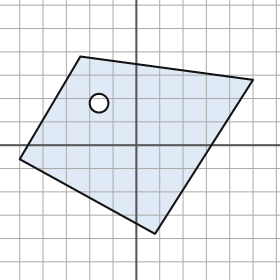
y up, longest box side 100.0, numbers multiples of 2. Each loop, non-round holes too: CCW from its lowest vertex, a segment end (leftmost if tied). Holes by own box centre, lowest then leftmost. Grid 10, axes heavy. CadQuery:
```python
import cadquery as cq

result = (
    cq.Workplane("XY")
    .moveTo(8.0, -38.0)
    .lineTo(50.0, 28.0)
    .lineTo(-24.0, 38.0)
    .lineTo(-50.0, -6.0)
    .close()
    .moveTo(-16.0, 18.0)
    .circle(4.0)
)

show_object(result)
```